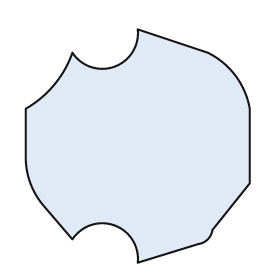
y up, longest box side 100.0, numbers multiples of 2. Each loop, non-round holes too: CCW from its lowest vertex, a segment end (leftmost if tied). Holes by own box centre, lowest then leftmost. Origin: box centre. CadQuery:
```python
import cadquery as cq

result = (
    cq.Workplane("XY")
    .moveTo(0.0, -50.0)
    .lineTo(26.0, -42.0)
    .threePointArc((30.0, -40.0), (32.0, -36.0))
    .lineTo(48.0, -16.0)
    .lineTo(48.0, 16.0)
    .threePointArc((42.0, 30.0), (30.0, 40.0))
    .lineTo(0.0, 50.0)
    .threePointArc((-10.0, 34.0), (-28.0, 40.0))
    .threePointArc((-36.0, 26.0), (-48.0, 16.0))
    .lineTo(-48.0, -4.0)
    .threePointArc((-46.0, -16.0), (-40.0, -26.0))
    .lineTo(-28.0, -40.0)
    .threePointArc((-10.0, -34.0), (0.0, -50.0))
    .close()
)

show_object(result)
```